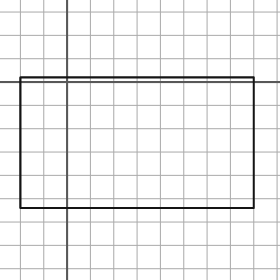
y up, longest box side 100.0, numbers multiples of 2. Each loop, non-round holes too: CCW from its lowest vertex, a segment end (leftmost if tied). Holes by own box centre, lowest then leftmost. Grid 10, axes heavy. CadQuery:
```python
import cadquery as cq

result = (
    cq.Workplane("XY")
    .moveTo(-20.0, -54.0)
    .lineTo(80.0, -54.0)
    .lineTo(80.0, 2.0)
    .lineTo(-20.0, 2.0)
    .close()
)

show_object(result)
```